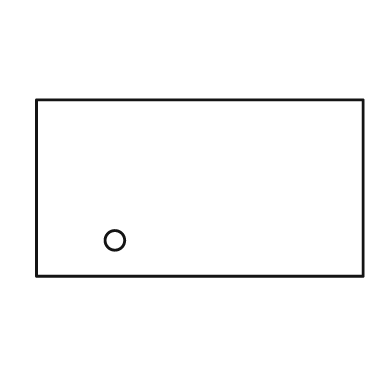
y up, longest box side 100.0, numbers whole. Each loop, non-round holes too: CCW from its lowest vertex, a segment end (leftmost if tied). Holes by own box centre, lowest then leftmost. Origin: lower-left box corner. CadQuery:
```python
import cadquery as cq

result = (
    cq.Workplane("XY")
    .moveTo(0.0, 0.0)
    .lineTo(100.0, 0.0)
    .lineTo(100.0, 54.0)
    .lineTo(0.0, 54.0)
    .close()
    .moveTo(24.0, 11.0)
    .circle(3.0)
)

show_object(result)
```